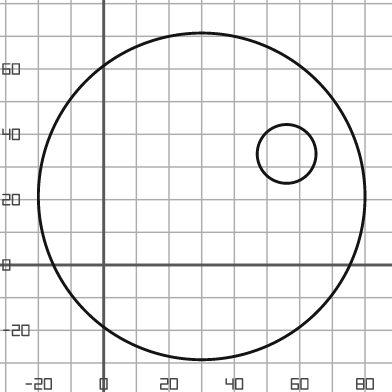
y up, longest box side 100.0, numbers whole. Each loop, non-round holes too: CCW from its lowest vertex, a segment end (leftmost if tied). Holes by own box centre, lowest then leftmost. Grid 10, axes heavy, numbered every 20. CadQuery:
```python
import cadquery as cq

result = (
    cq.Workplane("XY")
    .moveTo(30.0, 21.0)
    .circle(50.0)
    .moveTo(56.0, 34.0)
    .circle(9.0)
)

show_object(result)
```